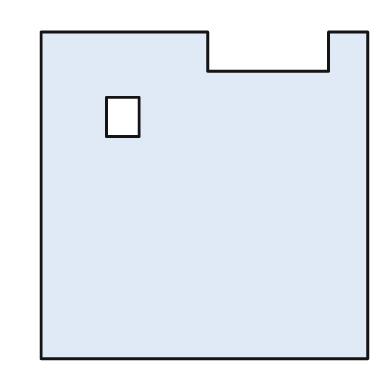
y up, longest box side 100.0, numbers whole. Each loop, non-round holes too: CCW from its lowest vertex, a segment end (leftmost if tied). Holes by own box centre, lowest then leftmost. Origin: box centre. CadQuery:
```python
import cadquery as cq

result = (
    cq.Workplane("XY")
    .moveTo(-50.0, -50.0)
    .lineTo(50.0, -50.0)
    .lineTo(50.0, 50.0)
    .lineTo(38.0, 50.0)
    .lineTo(38.0, 38.0)
    .lineTo(1.0, 38.0)
    .lineTo(1.0, 50.0)
    .lineTo(-50.0, 50.0)
    .close()
    .moveTo(-30.0, 18.0)
    .lineTo(-20.0, 18.0)
    .lineTo(-20.0, 30.0)
    .lineTo(-30.0, 30.0)
    .close()
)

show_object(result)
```